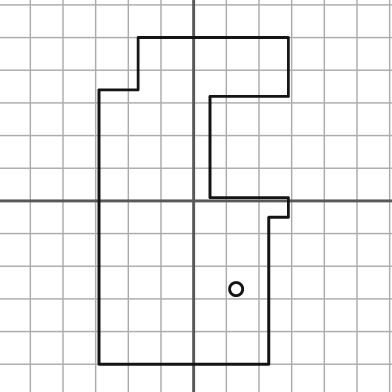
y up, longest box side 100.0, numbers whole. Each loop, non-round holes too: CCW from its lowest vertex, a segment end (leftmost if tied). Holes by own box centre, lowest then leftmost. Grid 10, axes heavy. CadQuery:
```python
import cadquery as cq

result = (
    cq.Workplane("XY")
    .moveTo(-29.0, -50.0)
    .lineTo(23.0, -50.0)
    .lineTo(23.0, -5.0)
    .lineTo(29.0, -5.0)
    .lineTo(29.0, 1.0)
    .lineTo(5.0, 1.0)
    .lineTo(5.0, 32.0)
    .lineTo(29.0, 32.0)
    .lineTo(29.0, 50.0)
    .lineTo(-17.0, 50.0)
    .lineTo(-17.0, 34.0)
    .lineTo(-29.0, 34.0)
    .close()
    .moveTo(13.0, -27.0)
    .circle(2.0)
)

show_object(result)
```